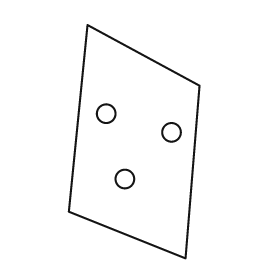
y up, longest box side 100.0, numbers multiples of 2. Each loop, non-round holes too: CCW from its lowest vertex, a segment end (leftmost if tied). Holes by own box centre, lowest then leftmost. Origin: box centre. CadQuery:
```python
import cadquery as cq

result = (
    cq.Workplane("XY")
    .moveTo(22.0, -50.0)
    .lineTo(28.0, 24.0)
    .lineTo(-20.0, 50.0)
    .lineTo(-28.0, -30.0)
    .close()
    .moveTo(-4.0, -16.0)
    .circle(4.0)
    .moveTo(16.0, 4.0)
    .circle(4.0)
    .moveTo(-12.0, 12.0)
    .circle(4.0)
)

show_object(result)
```